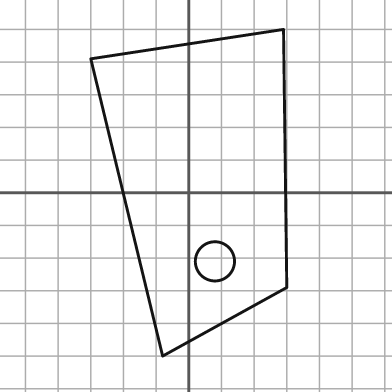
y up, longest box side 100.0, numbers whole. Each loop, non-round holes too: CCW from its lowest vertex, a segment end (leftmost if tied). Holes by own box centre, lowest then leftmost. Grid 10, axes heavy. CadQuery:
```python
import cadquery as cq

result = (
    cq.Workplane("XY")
    .moveTo(-8.0, -50.0)
    .lineTo(30.0, -29.0)
    .lineTo(29.0, 50.0)
    .lineTo(-30.0, 41.0)
    .close()
    .moveTo(8.0, -21.0)
    .circle(6.0)
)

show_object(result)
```